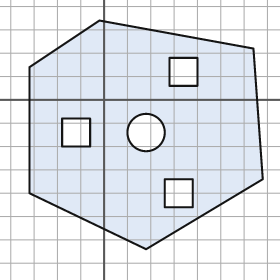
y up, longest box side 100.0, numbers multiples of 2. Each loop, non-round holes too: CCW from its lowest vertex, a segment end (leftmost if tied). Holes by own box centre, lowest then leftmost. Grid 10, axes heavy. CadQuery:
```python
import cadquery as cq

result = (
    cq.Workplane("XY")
    .moveTo(18.0, -64.0)
    .lineTo(68.0, -34.0)
    .lineTo(64.0, 22.0)
    .lineTo(-2.0, 34.0)
    .lineTo(-32.0, 14.0)
    .lineTo(-32.0, -40.0)
    .close()
    .moveTo(26.0, -46.0)
    .lineTo(38.0, -46.0)
    .lineTo(38.0, -34.0)
    .lineTo(26.0, -34.0)
    .close()
    .moveTo(-18.0, -20.0)
    .lineTo(-6.0, -20.0)
    .lineTo(-6.0, -8.0)
    .lineTo(-18.0, -8.0)
    .close()
    .moveTo(18.0, -14.0)
    .circle(8.0)
    .moveTo(28.0, 6.0)
    .lineTo(40.0, 6.0)
    .lineTo(40.0, 18.0)
    .lineTo(28.0, 18.0)
    .close()
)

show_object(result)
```